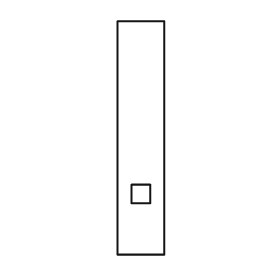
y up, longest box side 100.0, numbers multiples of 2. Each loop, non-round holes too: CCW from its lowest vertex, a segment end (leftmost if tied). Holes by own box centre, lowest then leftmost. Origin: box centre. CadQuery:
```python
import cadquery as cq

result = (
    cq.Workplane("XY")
    .moveTo(-10.0, -50.0)
    .lineTo(10.0, -50.0)
    .lineTo(10.0, 50.0)
    .lineTo(-10.0, 50.0)
    .close()
    .moveTo(-4.0, -28.0)
    .lineTo(4.0, -28.0)
    .lineTo(4.0, -20.0)
    .lineTo(-4.0, -20.0)
    .close()
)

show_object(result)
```